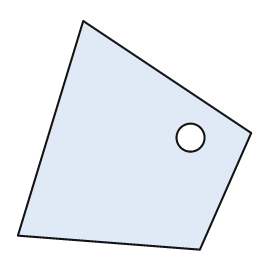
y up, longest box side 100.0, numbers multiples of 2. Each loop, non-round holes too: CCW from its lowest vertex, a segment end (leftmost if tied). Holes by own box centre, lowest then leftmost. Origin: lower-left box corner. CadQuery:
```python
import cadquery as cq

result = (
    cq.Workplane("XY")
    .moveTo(78.0, 0.0)
    .lineTo(100.0, 50.0)
    .lineTo(28.0, 98.0)
    .lineTo(0.0, 6.0)
    .close()
    .moveTo(74.0, 48.0)
    .circle(6.0)
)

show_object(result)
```